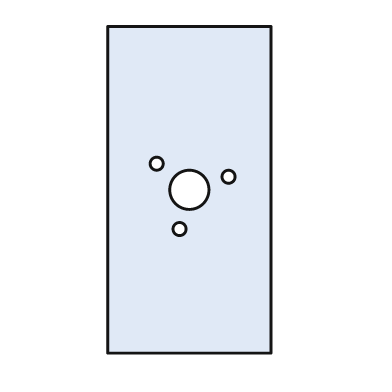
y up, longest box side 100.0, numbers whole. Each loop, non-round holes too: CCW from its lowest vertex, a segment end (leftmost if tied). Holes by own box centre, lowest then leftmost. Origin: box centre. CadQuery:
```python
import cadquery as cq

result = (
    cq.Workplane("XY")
    .moveTo(-25.0, -50.0)
    .lineTo(25.0, -50.0)
    .lineTo(25.0, 50.0)
    .lineTo(-25.0, 50.0)
    .close()
    .moveTo(-3.0, -12.0)
    .circle(2.0)
    .moveTo(0.0, 0.0)
    .circle(6.0)
    .moveTo(12.0, 4.0)
    .circle(2.0)
    .moveTo(-10.0, 8.0)
    .circle(2.0)
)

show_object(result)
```